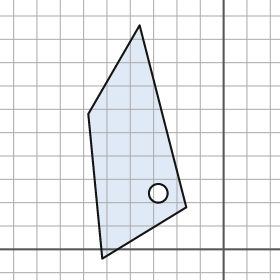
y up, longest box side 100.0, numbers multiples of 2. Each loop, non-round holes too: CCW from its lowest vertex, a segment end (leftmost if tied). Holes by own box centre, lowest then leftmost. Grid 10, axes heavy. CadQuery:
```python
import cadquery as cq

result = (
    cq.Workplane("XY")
    .moveTo(-52.0, -4.0)
    .lineTo(-16.0, 18.0)
    .lineTo(-36.0, 96.0)
    .lineTo(-58.0, 58.0)
    .close()
    .moveTo(-28.0, 24.0)
    .circle(4.0)
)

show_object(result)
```